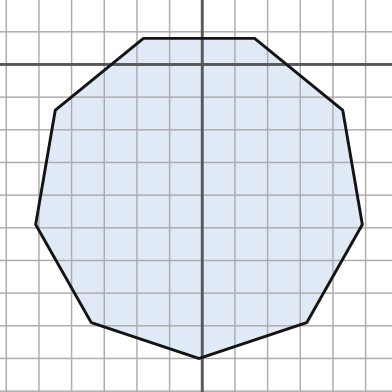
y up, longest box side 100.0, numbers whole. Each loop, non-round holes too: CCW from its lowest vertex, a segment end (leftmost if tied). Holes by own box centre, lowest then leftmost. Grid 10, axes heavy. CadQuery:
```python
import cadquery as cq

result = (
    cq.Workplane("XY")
    .moveTo(-1.0, -90.0)
    .lineTo(32.0, -79.0)
    .lineTo(49.0, -49.0)
    .lineTo(43.0, -14.0)
    .lineTo(16.0, 8.0)
    .lineTo(-18.0, 8.0)
    .lineTo(-45.0, -14.0)
    .lineTo(-51.0, -49.0)
    .lineTo(-34.0, -79.0)
    .close()
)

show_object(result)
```